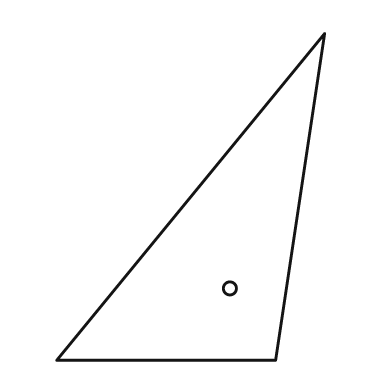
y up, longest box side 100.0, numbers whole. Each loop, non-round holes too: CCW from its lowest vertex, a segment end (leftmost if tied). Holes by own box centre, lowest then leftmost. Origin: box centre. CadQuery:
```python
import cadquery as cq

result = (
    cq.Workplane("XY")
    .moveTo(-41.0, -50.0)
    .lineTo(26.0, -50.0)
    .lineTo(41.0, 50.0)
    .close()
    .moveTo(12.0, -28.0)
    .circle(2.0)
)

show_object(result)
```